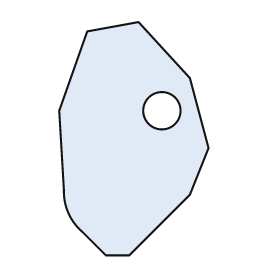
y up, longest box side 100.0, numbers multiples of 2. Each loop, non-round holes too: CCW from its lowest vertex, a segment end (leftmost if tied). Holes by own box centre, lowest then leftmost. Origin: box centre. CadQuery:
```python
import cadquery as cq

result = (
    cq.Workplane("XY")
    .moveTo(-12.0, -50.0)
    .lineTo(-2.0, -50.0)
    .lineTo(24.0, -24.0)
    .lineTo(32.0, -4.0)
    .lineTo(24.0, 26.0)
    .lineTo(2.0, 50.0)
    .lineTo(-20.0, 46.0)
    .lineTo(-32.0, 12.0)
    .lineTo(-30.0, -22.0)
    .threePointArc((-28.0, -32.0), (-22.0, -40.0))
    .close()
    .moveTo(12.0, 12.0)
    .circle(8.0)
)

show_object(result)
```